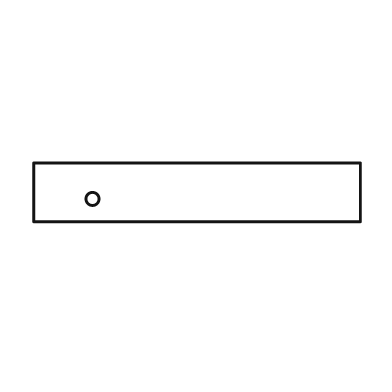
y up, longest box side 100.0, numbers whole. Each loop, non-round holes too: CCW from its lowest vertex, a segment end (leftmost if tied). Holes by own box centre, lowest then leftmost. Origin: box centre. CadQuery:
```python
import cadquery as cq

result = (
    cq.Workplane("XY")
    .moveTo(-50.0, -9.0)
    .lineTo(50.0, -9.0)
    .lineTo(50.0, 9.0)
    .lineTo(-50.0, 9.0)
    .close()
    .moveTo(-32.0, -2.0)
    .circle(2.0)
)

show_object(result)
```